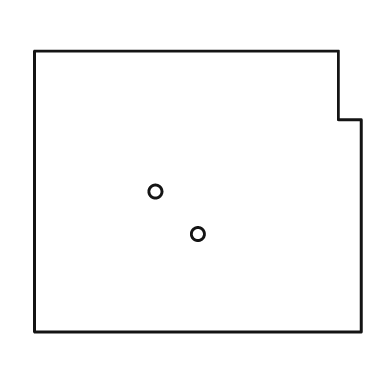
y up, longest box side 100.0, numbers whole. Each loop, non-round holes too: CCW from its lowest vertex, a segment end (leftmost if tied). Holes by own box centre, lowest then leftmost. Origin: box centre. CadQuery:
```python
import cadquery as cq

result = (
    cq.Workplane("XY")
    .moveTo(-50.0, -43.0)
    .lineTo(50.0, -43.0)
    .lineTo(50.0, 22.0)
    .lineTo(43.0, 22.0)
    .lineTo(43.0, 43.0)
    .lineTo(-50.0, 43.0)
    .close()
    .moveTo(0.0, -13.0)
    .circle(2.0)
    .moveTo(-13.0, 0.0)
    .circle(2.0)
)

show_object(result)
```